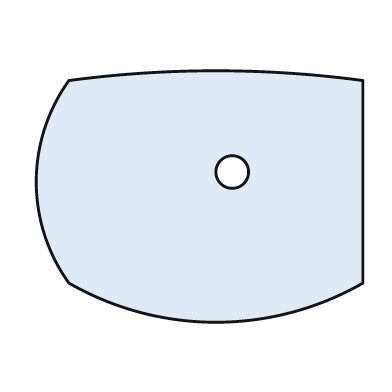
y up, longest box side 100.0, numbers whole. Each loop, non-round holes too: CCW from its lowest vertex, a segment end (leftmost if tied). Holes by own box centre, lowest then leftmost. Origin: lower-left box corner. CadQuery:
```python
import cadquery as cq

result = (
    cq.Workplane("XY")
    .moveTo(10.0, 12.0)
    .threePointArc((55.0, 0.0), (100.0, 12.0))
    .lineTo(100.0, 74.0)
    .threePointArc((55.0, 77.0), (10.0, 74.0))
    .threePointArc((0.0, 43.0), (10.0, 12.0))
    .close()
    .moveTo(60.0, 46.0)
    .circle(5.0)
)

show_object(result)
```